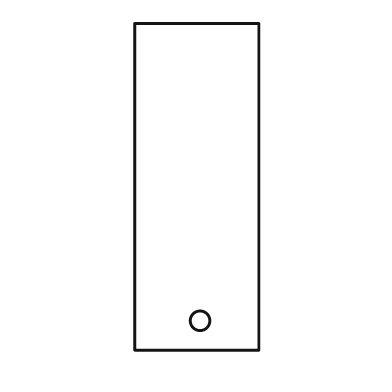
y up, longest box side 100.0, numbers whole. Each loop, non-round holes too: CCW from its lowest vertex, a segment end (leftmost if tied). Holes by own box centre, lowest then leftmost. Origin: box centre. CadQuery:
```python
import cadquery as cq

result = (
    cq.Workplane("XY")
    .moveTo(-19.0, -50.0)
    .lineTo(19.0, -50.0)
    .lineTo(19.0, 50.0)
    .lineTo(-19.0, 50.0)
    .close()
    .moveTo(1.0, -41.0)
    .circle(3.0)
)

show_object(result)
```